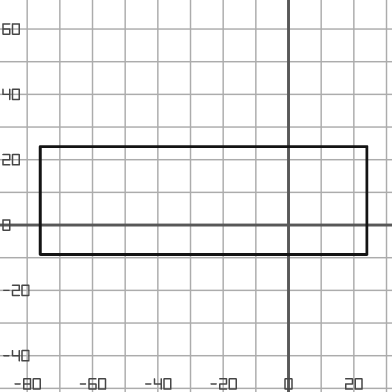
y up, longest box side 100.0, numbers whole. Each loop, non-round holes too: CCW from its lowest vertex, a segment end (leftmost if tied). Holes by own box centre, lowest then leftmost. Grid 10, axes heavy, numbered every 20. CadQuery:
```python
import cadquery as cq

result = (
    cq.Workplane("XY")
    .moveTo(-76.0, -9.0)
    .lineTo(24.0, -9.0)
    .lineTo(24.0, 24.0)
    .lineTo(-76.0, 24.0)
    .close()
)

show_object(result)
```